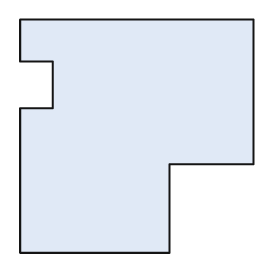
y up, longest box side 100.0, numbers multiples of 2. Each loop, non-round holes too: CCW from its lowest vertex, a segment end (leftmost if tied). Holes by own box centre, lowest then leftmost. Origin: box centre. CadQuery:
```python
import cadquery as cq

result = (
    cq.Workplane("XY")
    .moveTo(-50.0, -50.0)
    .lineTo(14.0, -50.0)
    .lineTo(14.0, -12.0)
    .lineTo(50.0, -12.0)
    .lineTo(50.0, 50.0)
    .lineTo(-50.0, 50.0)
    .lineTo(-50.0, 32.0)
    .lineTo(-36.0, 32.0)
    .lineTo(-36.0, 12.0)
    .lineTo(-50.0, 12.0)
    .close()
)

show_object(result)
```